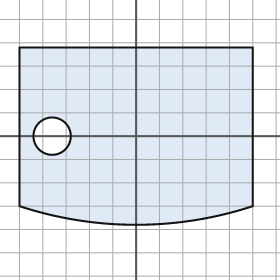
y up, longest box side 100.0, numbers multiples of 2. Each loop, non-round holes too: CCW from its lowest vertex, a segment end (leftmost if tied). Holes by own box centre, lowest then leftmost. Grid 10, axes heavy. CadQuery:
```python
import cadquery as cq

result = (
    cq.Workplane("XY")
    .moveTo(-50.0, -30.0)
    .threePointArc((0.0, -38.0), (50.0, -30.0))
    .lineTo(50.0, 38.0)
    .lineTo(-50.0, 38.0)
    .close()
    .moveTo(-36.0, 0.0)
    .circle(8.0)
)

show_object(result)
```